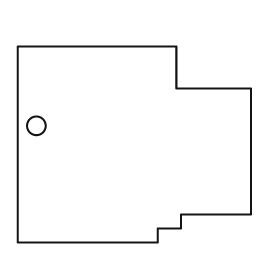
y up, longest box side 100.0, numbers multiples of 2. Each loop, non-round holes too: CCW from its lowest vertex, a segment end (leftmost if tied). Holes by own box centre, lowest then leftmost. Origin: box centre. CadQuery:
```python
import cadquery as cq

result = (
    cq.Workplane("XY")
    .moveTo(-50.0, -42.0)
    .lineTo(10.0, -42.0)
    .lineTo(10.0, -36.0)
    .lineTo(20.0, -36.0)
    .lineTo(20.0, -30.0)
    .lineTo(50.0, -30.0)
    .lineTo(50.0, 24.0)
    .lineTo(18.0, 24.0)
    .lineTo(18.0, 42.0)
    .lineTo(-50.0, 42.0)
    .close()
    .moveTo(-42.0, 8.0)
    .circle(4.0)
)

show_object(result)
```